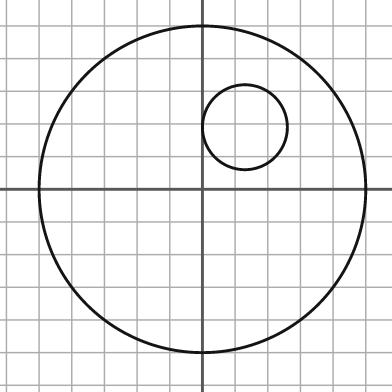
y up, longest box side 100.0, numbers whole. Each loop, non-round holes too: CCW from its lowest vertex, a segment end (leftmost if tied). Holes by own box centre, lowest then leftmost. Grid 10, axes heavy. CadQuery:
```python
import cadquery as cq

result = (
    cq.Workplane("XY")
    .moveTo(0.0, 0.0)
    .circle(50.0)
    .moveTo(13.0, 19.0)
    .circle(13.0)
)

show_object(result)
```